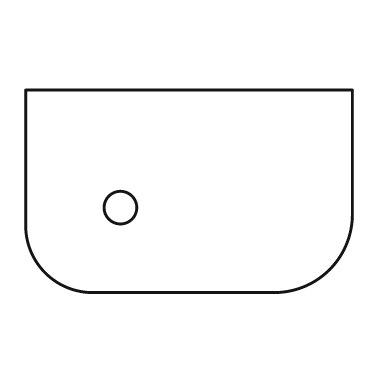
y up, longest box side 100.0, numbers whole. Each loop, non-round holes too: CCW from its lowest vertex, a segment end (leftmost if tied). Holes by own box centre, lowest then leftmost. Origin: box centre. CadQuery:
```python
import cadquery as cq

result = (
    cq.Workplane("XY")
    .moveTo(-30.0, -31.0)
    .lineTo(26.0, -31.0)
    .threePointArc((43.0, -24.0), (50.0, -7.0))
    .lineTo(50.0, 31.0)
    .lineTo(-50.0, 31.0)
    .lineTo(-50.0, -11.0)
    .threePointArc((-44.0, -25.0), (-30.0, -31.0))
    .close()
    .moveTo(-21.0, -5.0)
    .circle(5.0)
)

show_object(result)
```